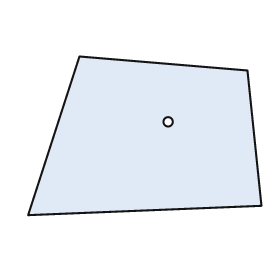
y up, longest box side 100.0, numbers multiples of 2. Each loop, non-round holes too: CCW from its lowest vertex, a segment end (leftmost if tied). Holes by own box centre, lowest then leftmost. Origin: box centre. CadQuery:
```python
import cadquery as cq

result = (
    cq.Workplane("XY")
    .moveTo(-50.0, -34.0)
    .lineTo(50.0, -30.0)
    .lineTo(44.0, 28.0)
    .lineTo(-28.0, 34.0)
    .close()
    .moveTo(10.0, 6.0)
    .circle(2.0)
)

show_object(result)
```